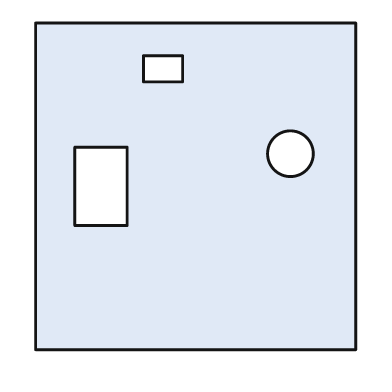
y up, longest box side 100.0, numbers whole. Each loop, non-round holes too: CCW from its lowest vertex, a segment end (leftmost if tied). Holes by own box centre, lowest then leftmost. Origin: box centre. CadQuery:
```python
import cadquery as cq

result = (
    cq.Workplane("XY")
    .moveTo(-49.0, -50.0)
    .lineTo(49.0, -50.0)
    .lineTo(49.0, 50.0)
    .lineTo(-49.0, 50.0)
    .close()
    .moveTo(-37.0, -12.0)
    .lineTo(-21.0, -12.0)
    .lineTo(-21.0, 12.0)
    .lineTo(-37.0, 12.0)
    .close()
    .moveTo(29.0, 10.0)
    .circle(7.0)
    .moveTo(-16.0, 32.0)
    .lineTo(-4.0, 32.0)
    .lineTo(-4.0, 40.0)
    .lineTo(-16.0, 40.0)
    .close()
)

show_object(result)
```